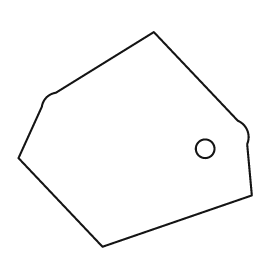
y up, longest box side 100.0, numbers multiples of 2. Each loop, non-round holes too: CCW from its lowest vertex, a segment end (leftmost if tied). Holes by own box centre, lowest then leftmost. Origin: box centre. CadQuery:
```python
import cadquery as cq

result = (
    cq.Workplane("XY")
    .moveTo(-14.0, -46.0)
    .lineTo(50.0, -24.0)
    .lineTo(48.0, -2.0)
    .threePointArc((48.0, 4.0), (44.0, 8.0))
    .lineTo(8.0, 46.0)
    .lineTo(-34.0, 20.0)
    .threePointArc((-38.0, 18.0), (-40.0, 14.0))
    .lineTo(-50.0, -8.0)
    .close()
    .moveTo(30.0, -4.0)
    .circle(4.0)
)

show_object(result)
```